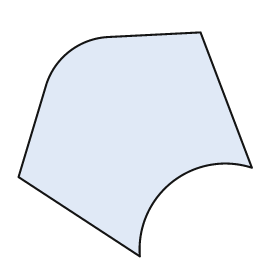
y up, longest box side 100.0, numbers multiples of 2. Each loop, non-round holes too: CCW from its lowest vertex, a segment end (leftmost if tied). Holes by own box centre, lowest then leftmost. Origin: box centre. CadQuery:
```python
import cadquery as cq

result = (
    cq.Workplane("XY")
    .moveTo(2.0, -48.0)
    .threePointArc((16.0, -16.0), (50.0, -10.0))
    .lineTo(28.0, 48.0)
    .lineTo(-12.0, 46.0)
    .threePointArc((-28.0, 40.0), (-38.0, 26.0))
    .lineTo(-50.0, -14.0)
    .close()
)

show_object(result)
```